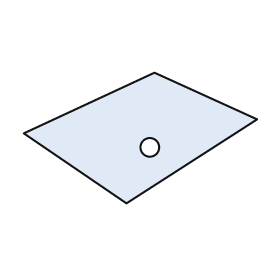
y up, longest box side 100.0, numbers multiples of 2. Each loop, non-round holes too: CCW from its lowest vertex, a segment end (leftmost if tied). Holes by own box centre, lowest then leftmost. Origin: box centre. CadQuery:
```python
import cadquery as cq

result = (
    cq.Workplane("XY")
    .moveTo(-6.0, -28.0)
    .lineTo(50.0, 8.0)
    .lineTo(6.0, 28.0)
    .lineTo(-50.0, 2.0)
    .close()
    .moveTo(4.0, -4.0)
    .circle(4.0)
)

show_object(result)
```